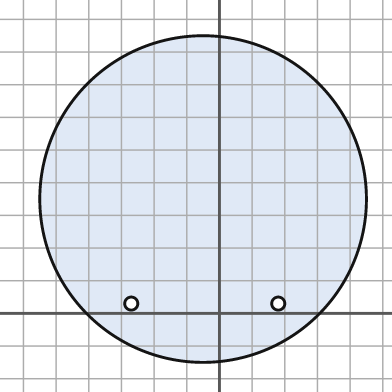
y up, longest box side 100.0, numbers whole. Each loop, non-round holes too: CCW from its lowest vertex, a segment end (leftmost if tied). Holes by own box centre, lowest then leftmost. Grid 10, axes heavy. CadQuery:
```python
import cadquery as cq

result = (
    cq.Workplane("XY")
    .moveTo(-5.0, 35.0)
    .circle(50.0)
    .moveTo(-27.0, 3.0)
    .circle(2.0)
    .moveTo(18.0, 3.0)
    .circle(2.0)
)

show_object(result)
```